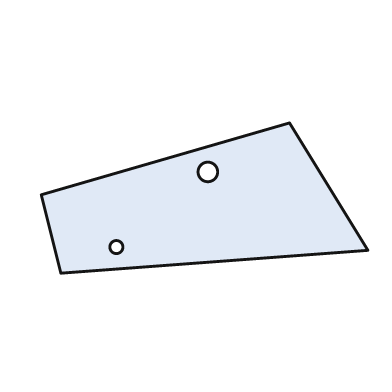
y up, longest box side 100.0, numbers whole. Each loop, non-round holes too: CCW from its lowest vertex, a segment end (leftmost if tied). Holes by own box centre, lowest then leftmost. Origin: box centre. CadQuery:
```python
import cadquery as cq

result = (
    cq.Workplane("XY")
    .moveTo(-44.0, -23.0)
    .lineTo(50.0, -16.0)
    .lineTo(26.0, 23.0)
    .lineTo(-50.0, 1.0)
    .close()
    .moveTo(-27.0, -15.0)
    .circle(2.0)
    .moveTo(1.0, 8.0)
    .circle(3.0)
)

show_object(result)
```